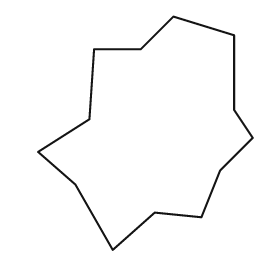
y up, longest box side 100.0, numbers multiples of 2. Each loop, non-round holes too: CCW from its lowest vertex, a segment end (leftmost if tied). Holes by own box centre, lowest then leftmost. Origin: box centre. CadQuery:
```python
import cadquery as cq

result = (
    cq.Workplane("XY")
    .moveTo(-14.0, -50.0)
    .lineTo(4.0, -34.0)
    .lineTo(24.0, -36.0)
    .lineTo(32.0, -16.0)
    .lineTo(46.0, -2.0)
    .lineTo(38.0, 10.0)
    .lineTo(38.0, 42.0)
    .lineTo(12.0, 50.0)
    .lineTo(-2.0, 36.0)
    .lineTo(-22.0, 36.0)
    .lineTo(-24.0, 6.0)
    .lineTo(-46.0, -8.0)
    .lineTo(-30.0, -22.0)
    .close()
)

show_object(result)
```